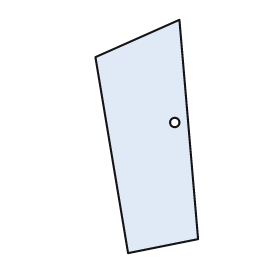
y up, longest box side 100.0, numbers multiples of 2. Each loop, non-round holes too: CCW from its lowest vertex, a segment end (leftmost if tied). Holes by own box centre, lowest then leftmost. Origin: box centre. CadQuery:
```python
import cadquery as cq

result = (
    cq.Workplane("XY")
    .moveTo(-8.0, -50.0)
    .lineTo(22.0, -44.0)
    .lineTo(14.0, 50.0)
    .lineTo(-22.0, 34.0)
    .close()
    .moveTo(12.0, 6.0)
    .circle(2.0)
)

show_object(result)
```